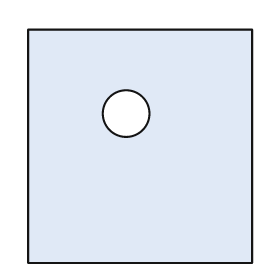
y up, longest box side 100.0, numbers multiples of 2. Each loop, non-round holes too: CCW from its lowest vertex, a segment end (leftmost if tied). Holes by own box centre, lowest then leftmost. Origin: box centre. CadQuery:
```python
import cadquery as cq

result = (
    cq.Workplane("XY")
    .moveTo(-48.0, -50.0)
    .lineTo(48.0, -50.0)
    .lineTo(48.0, 50.0)
    .lineTo(-48.0, 50.0)
    .close()
    .moveTo(-6.0, 14.0)
    .circle(10.0)
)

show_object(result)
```